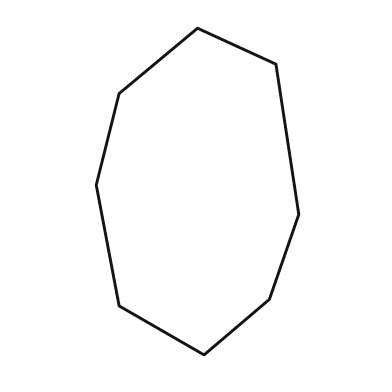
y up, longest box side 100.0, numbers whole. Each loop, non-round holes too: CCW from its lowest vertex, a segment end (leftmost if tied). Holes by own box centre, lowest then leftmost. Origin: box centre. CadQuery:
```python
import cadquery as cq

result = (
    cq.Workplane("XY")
    .moveTo(2.0, -50.0)
    .lineTo(22.0, -33.0)
    .lineTo(31.0, -7.0)
    .lineTo(24.0, 39.0)
    .lineTo(0.0, 50.0)
    .lineTo(-24.0, 30.0)
    .lineTo(-31.0, 2.0)
    .lineTo(-24.0, -35.0)
    .close()
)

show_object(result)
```